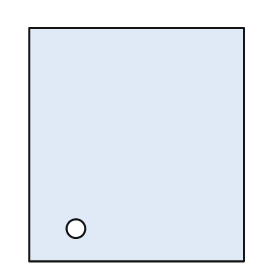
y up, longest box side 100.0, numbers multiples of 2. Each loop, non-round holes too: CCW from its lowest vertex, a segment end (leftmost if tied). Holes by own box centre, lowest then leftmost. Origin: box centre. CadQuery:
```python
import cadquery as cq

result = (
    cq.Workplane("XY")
    .moveTo(-46.0, -50.0)
    .lineTo(46.0, -50.0)
    .lineTo(46.0, 50.0)
    .lineTo(-46.0, 50.0)
    .close()
    .moveTo(-26.0, -36.0)
    .circle(4.0)
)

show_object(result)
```